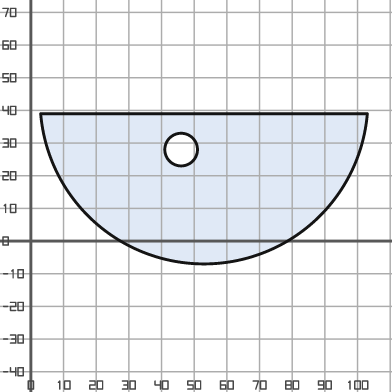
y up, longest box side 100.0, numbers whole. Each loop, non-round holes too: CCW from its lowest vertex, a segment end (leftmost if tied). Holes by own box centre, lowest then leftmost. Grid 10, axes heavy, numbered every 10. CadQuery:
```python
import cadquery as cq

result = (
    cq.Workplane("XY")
    .moveTo(3.0, 39.0)
    .threePointArc((53.0, -7.0), (103.0, 39.0))
    .close()
    .moveTo(46.0, 28.0)
    .circle(5.0)
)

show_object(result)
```